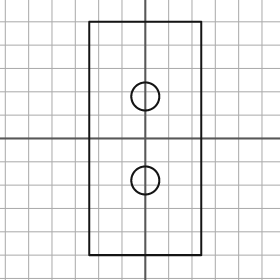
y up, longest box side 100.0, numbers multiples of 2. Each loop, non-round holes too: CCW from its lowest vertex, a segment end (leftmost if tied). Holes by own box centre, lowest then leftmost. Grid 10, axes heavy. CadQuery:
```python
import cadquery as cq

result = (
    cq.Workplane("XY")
    .moveTo(-24.0, -50.0)
    .lineTo(24.0, -50.0)
    .lineTo(24.0, 50.0)
    .lineTo(-24.0, 50.0)
    .close()
    .moveTo(0.0, -18.0)
    .circle(6.0)
    .moveTo(0.0, 18.0)
    .circle(6.0)
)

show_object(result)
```